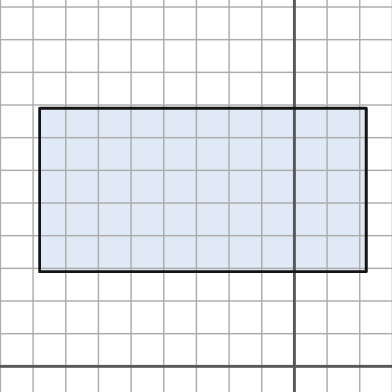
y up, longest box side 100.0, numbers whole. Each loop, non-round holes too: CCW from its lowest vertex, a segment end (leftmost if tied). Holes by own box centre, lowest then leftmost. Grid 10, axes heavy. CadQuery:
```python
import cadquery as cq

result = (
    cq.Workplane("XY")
    .moveTo(-78.0, 29.0)
    .lineTo(22.0, 29.0)
    .lineTo(22.0, 79.0)
    .lineTo(-78.0, 79.0)
    .close()
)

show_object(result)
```